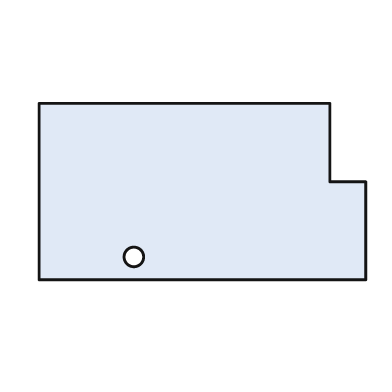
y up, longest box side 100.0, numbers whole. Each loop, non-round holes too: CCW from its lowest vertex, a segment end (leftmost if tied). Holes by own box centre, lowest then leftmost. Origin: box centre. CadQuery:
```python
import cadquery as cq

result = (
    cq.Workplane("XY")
    .moveTo(-50.0, -27.0)
    .lineTo(50.0, -27.0)
    .lineTo(50.0, 3.0)
    .lineTo(39.0, 3.0)
    .lineTo(39.0, 27.0)
    .lineTo(-50.0, 27.0)
    .close()
    .moveTo(-21.0, -20.0)
    .circle(3.0)
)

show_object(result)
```